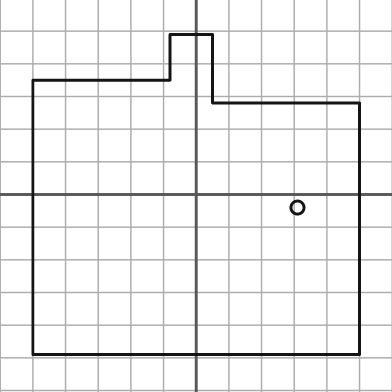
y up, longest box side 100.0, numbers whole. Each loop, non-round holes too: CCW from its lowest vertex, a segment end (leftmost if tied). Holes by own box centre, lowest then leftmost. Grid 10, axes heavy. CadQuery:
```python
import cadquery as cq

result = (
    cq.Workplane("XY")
    .moveTo(-50.0, -49.0)
    .lineTo(50.0, -49.0)
    .lineTo(50.0, 28.0)
    .lineTo(5.0, 28.0)
    .lineTo(5.0, 49.0)
    .lineTo(-8.0, 49.0)
    .lineTo(-8.0, 35.0)
    .lineTo(-50.0, 35.0)
    .close()
    .moveTo(31.0, -4.0)
    .circle(2.0)
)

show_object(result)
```